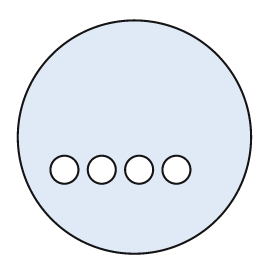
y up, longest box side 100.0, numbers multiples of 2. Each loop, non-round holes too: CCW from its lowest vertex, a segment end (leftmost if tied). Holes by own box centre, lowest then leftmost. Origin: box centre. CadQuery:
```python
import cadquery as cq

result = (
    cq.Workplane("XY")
    .moveTo(0.0, 0.0)
    .circle(50.0)
    .moveTo(-30.0, -14.0)
    .circle(6.0)
    .moveTo(-14.0, -14.0)
    .circle(6.0)
    .moveTo(2.0, -14.0)
    .circle(6.0)
    .moveTo(18.0, -14.0)
    .circle(6.0)
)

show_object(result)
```